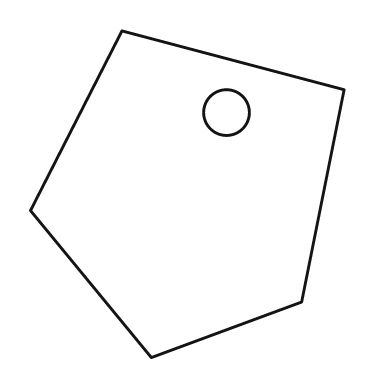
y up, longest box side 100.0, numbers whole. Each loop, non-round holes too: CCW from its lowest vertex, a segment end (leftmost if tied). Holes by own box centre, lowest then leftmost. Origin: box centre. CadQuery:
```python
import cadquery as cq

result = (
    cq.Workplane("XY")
    .moveTo(-11.0, -50.0)
    .lineTo(35.0, -33.0)
    .lineTo(48.0, 32.0)
    .lineTo(-20.0, 50.0)
    .lineTo(-48.0, -5.0)
    .close()
    .moveTo(12.0, 25.0)
    .circle(7.0)
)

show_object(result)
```